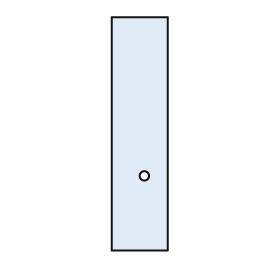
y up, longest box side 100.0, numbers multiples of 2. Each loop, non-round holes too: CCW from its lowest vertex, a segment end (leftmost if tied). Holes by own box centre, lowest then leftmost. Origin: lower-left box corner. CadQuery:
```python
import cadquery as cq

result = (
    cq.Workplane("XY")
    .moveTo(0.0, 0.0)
    .lineTo(24.0, 0.0)
    .lineTo(24.0, 100.0)
    .lineTo(0.0, 100.0)
    .close()
    .moveTo(14.0, 32.0)
    .circle(2.0)
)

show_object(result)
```